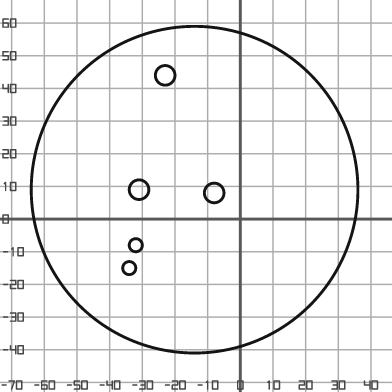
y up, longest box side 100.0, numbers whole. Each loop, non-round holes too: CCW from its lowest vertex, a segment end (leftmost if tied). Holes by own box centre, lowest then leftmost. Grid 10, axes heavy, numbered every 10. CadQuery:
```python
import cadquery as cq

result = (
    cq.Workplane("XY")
    .moveTo(-14.0, 9.0)
    .circle(50.0)
    .moveTo(-34.0, -15.0)
    .circle(2.0)
    .moveTo(-32.0, -8.0)
    .circle(2.0)
    .moveTo(-8.0, 8.0)
    .circle(3.0)
    .moveTo(-31.0, 9.0)
    .circle(3.0)
    .moveTo(-23.0, 44.0)
    .circle(3.0)
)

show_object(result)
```